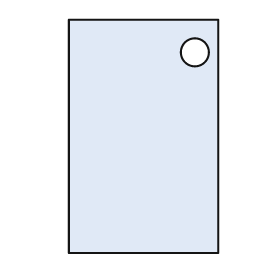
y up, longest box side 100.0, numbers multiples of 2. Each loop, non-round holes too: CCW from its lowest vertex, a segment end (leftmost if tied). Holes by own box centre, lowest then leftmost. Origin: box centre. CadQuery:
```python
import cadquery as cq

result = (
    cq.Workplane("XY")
    .moveTo(-32.0, -50.0)
    .lineTo(32.0, -50.0)
    .lineTo(32.0, 50.0)
    .lineTo(-32.0, 50.0)
    .close()
    .moveTo(22.0, 36.0)
    .circle(6.0)
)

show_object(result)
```